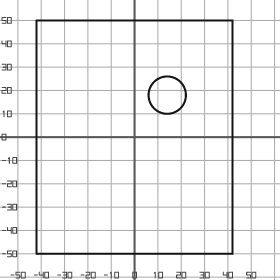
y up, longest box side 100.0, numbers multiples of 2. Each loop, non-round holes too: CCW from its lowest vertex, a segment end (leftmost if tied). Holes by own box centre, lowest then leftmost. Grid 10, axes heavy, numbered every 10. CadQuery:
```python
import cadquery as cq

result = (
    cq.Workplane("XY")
    .moveTo(-42.0, -50.0)
    .lineTo(42.0, -50.0)
    .lineTo(42.0, 50.0)
    .lineTo(-42.0, 50.0)
    .close()
    .moveTo(14.0, 18.0)
    .circle(8.0)
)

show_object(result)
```